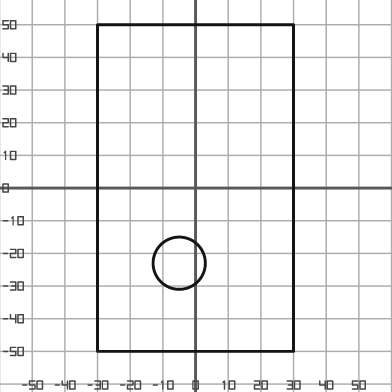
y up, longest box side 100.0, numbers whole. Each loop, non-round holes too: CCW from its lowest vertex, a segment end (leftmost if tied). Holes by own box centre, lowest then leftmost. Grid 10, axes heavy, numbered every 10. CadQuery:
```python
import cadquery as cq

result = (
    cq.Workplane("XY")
    .moveTo(-30.0, -50.0)
    .lineTo(30.0, -50.0)
    .lineTo(30.0, 50.0)
    .lineTo(-30.0, 50.0)
    .close()
    .moveTo(-5.0, -23.0)
    .circle(8.0)
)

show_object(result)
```